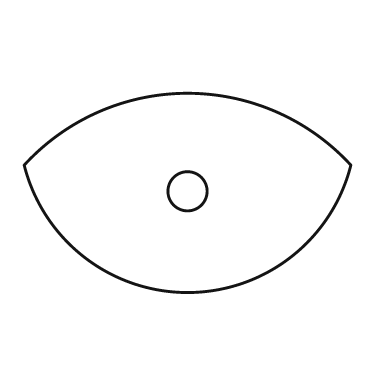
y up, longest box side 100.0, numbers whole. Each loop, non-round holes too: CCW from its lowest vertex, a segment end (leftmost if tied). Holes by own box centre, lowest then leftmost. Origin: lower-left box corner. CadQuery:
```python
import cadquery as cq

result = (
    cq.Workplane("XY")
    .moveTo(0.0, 39.0)
    .threePointArc((50.0, 0.0), (100.0, 39.0))
    .threePointArc((50.0, 61.0), (0.0, 39.0))
    .close()
    .moveTo(50.0, 31.0)
    .circle(6.0)
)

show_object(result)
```